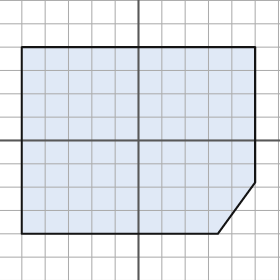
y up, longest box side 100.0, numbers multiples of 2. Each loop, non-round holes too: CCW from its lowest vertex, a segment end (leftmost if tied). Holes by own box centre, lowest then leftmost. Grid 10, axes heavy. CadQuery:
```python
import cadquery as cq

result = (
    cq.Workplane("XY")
    .moveTo(-50.0, -40.0)
    .lineTo(34.0, -40.0)
    .lineTo(50.0, -18.0)
    .lineTo(50.0, 40.0)
    .lineTo(-50.0, 40.0)
    .close()
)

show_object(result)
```